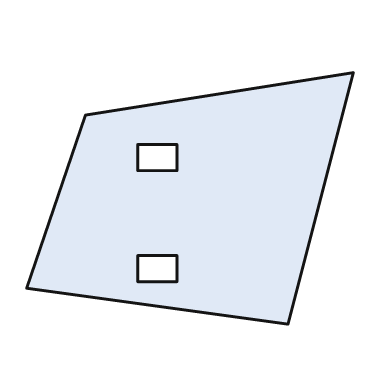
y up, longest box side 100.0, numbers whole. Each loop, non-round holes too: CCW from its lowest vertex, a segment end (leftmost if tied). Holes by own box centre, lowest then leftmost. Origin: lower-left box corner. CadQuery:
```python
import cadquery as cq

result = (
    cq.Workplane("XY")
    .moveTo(80.0, 0.0)
    .lineTo(100.0, 77.0)
    .lineTo(18.0, 64.0)
    .lineTo(0.0, 11.0)
    .close()
    .moveTo(34.0, 13.0)
    .lineTo(46.0, 13.0)
    .lineTo(46.0, 21.0)
    .lineTo(34.0, 21.0)
    .close()
    .moveTo(34.0, 47.0)
    .lineTo(46.0, 47.0)
    .lineTo(46.0, 55.0)
    .lineTo(34.0, 55.0)
    .close()
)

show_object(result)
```